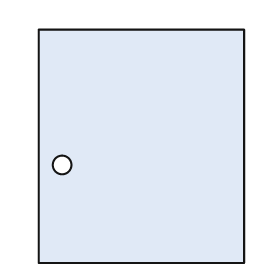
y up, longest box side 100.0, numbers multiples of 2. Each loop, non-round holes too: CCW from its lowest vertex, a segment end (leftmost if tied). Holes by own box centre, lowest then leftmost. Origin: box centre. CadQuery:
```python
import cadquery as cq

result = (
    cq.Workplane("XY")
    .moveTo(-44.0, -50.0)
    .lineTo(44.0, -50.0)
    .lineTo(44.0, 50.0)
    .lineTo(-44.0, 50.0)
    .close()
    .moveTo(-34.0, -8.0)
    .circle(4.0)
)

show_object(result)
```